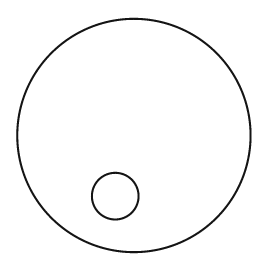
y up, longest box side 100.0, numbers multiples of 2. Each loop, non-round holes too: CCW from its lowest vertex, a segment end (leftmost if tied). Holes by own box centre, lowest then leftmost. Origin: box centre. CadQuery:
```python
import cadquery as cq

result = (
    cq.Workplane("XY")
    .moveTo(0.0, 0.0)
    .circle(50.0)
    .moveTo(-8.0, -26.0)
    .circle(10.0)
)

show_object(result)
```